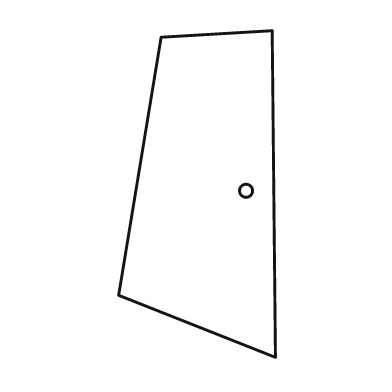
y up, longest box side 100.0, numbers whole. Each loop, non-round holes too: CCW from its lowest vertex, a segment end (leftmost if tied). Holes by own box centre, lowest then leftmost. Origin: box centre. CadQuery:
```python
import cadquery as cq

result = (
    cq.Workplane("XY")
    .moveTo(24.0, -50.0)
    .lineTo(23.0, 50.0)
    .lineTo(-11.0, 48.0)
    .lineTo(-24.0, -31.0)
    .close()
    .moveTo(15.0, 1.0)
    .circle(2.0)
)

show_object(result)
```